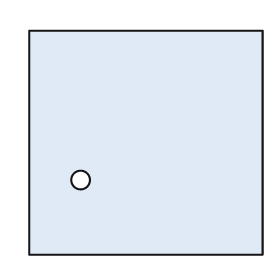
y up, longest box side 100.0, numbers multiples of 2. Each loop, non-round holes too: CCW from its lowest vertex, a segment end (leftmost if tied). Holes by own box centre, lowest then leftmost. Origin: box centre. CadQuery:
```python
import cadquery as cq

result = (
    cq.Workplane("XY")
    .moveTo(-50.0, -48.0)
    .lineTo(50.0, -48.0)
    .lineTo(50.0, 48.0)
    .lineTo(-50.0, 48.0)
    .close()
    .moveTo(-28.0, -16.0)
    .circle(4.0)
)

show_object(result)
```